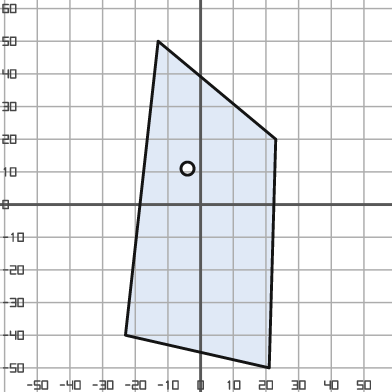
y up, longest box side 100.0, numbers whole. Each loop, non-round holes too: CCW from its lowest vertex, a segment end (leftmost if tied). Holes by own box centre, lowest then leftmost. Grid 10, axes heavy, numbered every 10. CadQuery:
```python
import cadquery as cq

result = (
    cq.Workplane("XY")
    .moveTo(21.0, -50.0)
    .lineTo(23.0, 20.0)
    .lineTo(-13.0, 50.0)
    .lineTo(-23.0, -40.0)
    .close()
    .moveTo(-4.0, 11.0)
    .circle(2.0)
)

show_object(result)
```